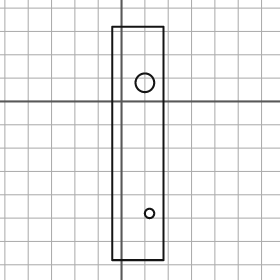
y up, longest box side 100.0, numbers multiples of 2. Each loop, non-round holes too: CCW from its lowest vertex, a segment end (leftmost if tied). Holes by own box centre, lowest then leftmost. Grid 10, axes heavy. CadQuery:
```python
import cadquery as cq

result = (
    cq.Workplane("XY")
    .moveTo(-4.0, -68.0)
    .lineTo(18.0, -68.0)
    .lineTo(18.0, 32.0)
    .lineTo(-4.0, 32.0)
    .close()
    .moveTo(12.0, -48.0)
    .circle(2.0)
    .moveTo(10.0, 8.0)
    .circle(4.0)
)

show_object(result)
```